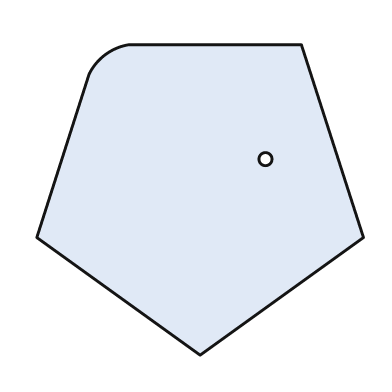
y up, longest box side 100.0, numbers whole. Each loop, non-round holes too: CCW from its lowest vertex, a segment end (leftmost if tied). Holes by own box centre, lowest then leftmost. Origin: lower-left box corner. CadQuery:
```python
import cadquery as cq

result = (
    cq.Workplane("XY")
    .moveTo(50.0, 0.0)
    .lineTo(100.0, 36.0)
    .lineTo(81.0, 95.0)
    .lineTo(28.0, 95.0)
    .threePointArc((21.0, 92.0), (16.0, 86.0))
    .lineTo(0.0, 36.0)
    .close()
    .moveTo(70.0, 60.0)
    .circle(2.0)
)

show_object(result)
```